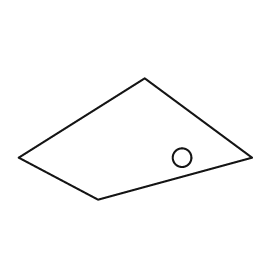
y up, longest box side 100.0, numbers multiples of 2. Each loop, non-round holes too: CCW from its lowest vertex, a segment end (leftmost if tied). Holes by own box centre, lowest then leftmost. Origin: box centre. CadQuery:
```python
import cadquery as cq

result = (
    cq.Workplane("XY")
    .moveTo(-16.0, -26.0)
    .lineTo(50.0, -8.0)
    .lineTo(4.0, 26.0)
    .lineTo(-50.0, -8.0)
    .close()
    .moveTo(20.0, -8.0)
    .circle(4.0)
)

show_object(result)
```